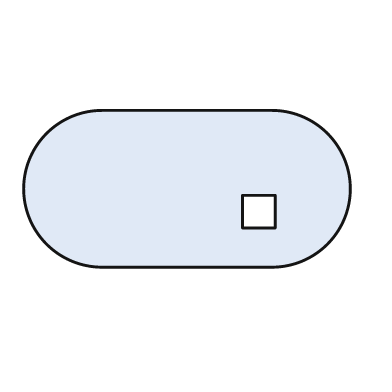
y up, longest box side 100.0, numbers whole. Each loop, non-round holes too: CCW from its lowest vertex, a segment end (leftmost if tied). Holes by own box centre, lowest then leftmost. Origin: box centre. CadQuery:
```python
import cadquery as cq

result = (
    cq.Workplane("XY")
    .moveTo(-26.0, -24.0)
    .lineTo(26.0, -24.0)
    .threePointArc((50.0, 0.0), (26.0, 24.0))
    .lineTo(-26.0, 24.0)
    .threePointArc((-50.0, 0.0), (-26.0, -24.0))
    .close()
    .moveTo(17.0, -12.0)
    .lineTo(27.0, -12.0)
    .lineTo(27.0, -2.0)
    .lineTo(17.0, -2.0)
    .close()
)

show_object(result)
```